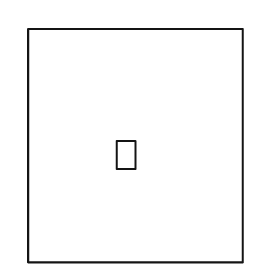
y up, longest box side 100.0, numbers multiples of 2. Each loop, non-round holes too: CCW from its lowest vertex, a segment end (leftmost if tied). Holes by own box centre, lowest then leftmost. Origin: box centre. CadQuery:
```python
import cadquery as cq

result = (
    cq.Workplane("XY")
    .moveTo(-46.0, -50.0)
    .lineTo(46.0, -50.0)
    .lineTo(46.0, 50.0)
    .lineTo(-46.0, 50.0)
    .close()
    .moveTo(-8.0, -10.0)
    .lineTo(0.0, -10.0)
    .lineTo(0.0, 2.0)
    .lineTo(-8.0, 2.0)
    .close()
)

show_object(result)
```